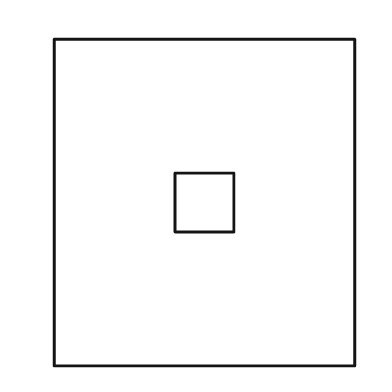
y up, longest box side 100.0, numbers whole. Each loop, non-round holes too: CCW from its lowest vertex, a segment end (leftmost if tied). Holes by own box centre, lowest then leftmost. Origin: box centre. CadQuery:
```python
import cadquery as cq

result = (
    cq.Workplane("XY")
    .moveTo(-46.0, -50.0)
    .lineTo(46.0, -50.0)
    .lineTo(46.0, 50.0)
    .lineTo(-46.0, 50.0)
    .close()
    .moveTo(-9.0, -9.0)
    .lineTo(9.0, -9.0)
    .lineTo(9.0, 9.0)
    .lineTo(-9.0, 9.0)
    .close()
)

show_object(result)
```